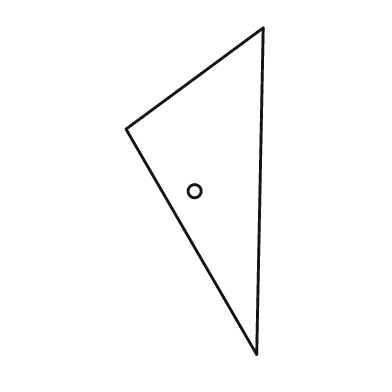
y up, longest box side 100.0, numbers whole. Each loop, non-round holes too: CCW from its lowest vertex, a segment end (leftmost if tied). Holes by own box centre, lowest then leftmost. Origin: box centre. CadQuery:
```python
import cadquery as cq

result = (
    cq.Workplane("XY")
    .moveTo(19.0, -50.0)
    .lineTo(21.0, 50.0)
    .lineTo(-21.0, 19.0)
    .close()
    .moveTo(0.0, 0.0)
    .circle(2.0)
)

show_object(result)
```